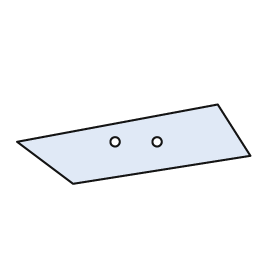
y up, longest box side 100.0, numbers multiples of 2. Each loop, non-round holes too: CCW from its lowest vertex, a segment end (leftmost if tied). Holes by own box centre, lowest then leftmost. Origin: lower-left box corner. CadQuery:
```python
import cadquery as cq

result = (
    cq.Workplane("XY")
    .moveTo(24.0, 0.0)
    .lineTo(100.0, 12.0)
    .lineTo(86.0, 34.0)
    .lineTo(0.0, 18.0)
    .close()
    .moveTo(42.0, 18.0)
    .circle(2.0)
    .moveTo(60.0, 18.0)
    .circle(2.0)
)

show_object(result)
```